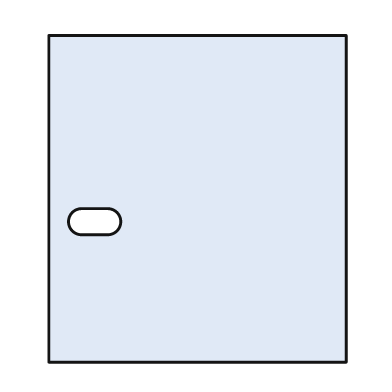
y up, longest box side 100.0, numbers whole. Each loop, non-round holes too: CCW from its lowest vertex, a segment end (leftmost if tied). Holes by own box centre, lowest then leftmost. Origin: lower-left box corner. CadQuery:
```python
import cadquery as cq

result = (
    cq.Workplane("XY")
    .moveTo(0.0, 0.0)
    .lineTo(91.0, 0.0)
    .lineTo(91.0, 100.0)
    .lineTo(0.0, 100.0)
    .close()
    .moveTo(10.0, 39.0)
    .lineTo(18.0, 39.0)
    .threePointArc((22.0, 43.0), (18.0, 47.0))
    .lineTo(10.0, 47.0)
    .threePointArc((6.0, 43.0), (10.0, 39.0))
    .close()
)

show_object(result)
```